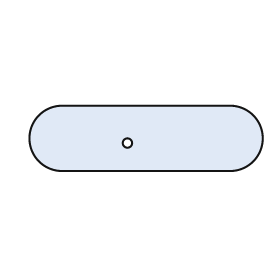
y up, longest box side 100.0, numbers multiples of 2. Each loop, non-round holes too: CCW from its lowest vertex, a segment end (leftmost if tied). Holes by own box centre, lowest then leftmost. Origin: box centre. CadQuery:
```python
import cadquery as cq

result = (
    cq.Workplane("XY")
    .moveTo(-36.0, -14.0)
    .lineTo(36.0, -14.0)
    .threePointArc((50.0, 0.0), (36.0, 14.0))
    .lineTo(-36.0, 14.0)
    .threePointArc((-50.0, 0.0), (-36.0, -14.0))
    .close()
    .moveTo(-8.0, -2.0)
    .circle(2.0)
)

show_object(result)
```